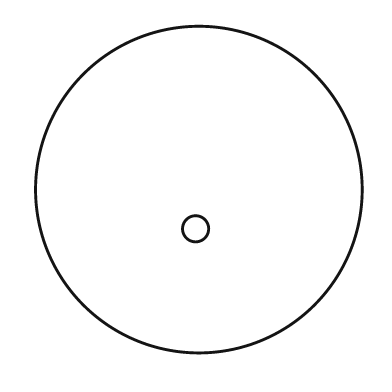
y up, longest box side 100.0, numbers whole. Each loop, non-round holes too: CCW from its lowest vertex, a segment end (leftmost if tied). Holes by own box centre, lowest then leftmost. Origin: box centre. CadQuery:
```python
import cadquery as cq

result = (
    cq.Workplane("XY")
    .moveTo(0.0, 0.0)
    .circle(50.0)
    .moveTo(-1.0, -12.0)
    .circle(4.0)
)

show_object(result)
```